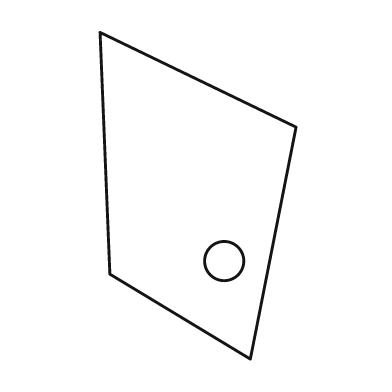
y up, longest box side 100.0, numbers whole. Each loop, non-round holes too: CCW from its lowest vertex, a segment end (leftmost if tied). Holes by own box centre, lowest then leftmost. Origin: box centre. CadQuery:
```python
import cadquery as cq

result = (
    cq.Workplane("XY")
    .moveTo(16.0, -50.0)
    .lineTo(30.0, 21.0)
    .lineTo(-30.0, 50.0)
    .lineTo(-27.0, -24.0)
    .close()
    .moveTo(8.0, -20.0)
    .circle(6.0)
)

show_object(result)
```